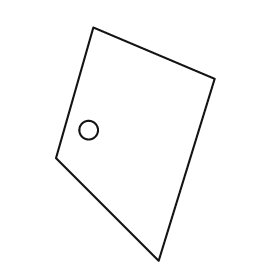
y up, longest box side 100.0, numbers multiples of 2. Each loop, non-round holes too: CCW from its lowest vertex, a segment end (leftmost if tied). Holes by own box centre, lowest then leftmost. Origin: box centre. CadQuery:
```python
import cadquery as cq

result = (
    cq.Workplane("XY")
    .moveTo(10.0, -50.0)
    .lineTo(34.0, 28.0)
    .lineTo(-18.0, 50.0)
    .lineTo(-34.0, -6.0)
    .close()
    .moveTo(-20.0, 6.0)
    .circle(4.0)
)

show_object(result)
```